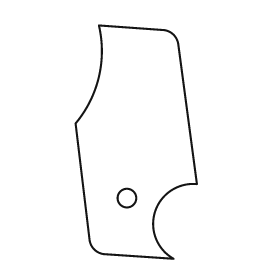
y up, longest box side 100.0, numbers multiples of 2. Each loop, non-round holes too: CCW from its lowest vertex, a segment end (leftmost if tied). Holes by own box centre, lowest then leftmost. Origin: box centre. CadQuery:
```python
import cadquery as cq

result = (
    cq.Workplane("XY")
    .moveTo(16.0, -50.0)
    .threePointArc((8.0, -30.0), (26.0, -18.0))
    .lineTo(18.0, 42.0)
    .threePointArc((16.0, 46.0), (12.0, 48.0))
    .lineTo(-16.0, 50.0)
    .threePointArc((-16.0, 28.0), (-26.0, 8.0))
    .lineTo(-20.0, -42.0)
    .threePointArc((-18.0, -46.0), (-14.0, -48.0))
    .close()
    .moveTo(-4.0, -24.0)
    .circle(4.0)
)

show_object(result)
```